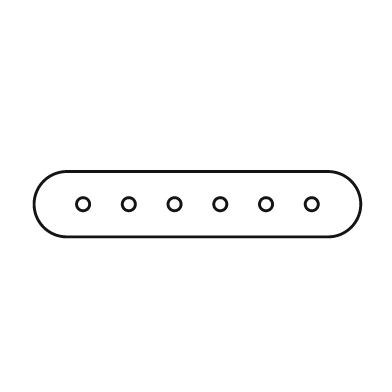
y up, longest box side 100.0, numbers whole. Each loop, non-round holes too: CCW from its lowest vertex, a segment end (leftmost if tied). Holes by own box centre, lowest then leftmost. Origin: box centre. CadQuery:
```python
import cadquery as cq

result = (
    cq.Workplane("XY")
    .moveTo(-40.0, -10.0)
    .lineTo(40.0, -10.0)
    .threePointArc((50.0, 0.0), (40.0, 10.0))
    .lineTo(-40.0, 10.0)
    .threePointArc((-50.0, 0.0), (-40.0, -10.0))
    .close()
    .moveTo(-35.0, 0.0)
    .circle(2.0)
    .moveTo(-21.0, 0.0)
    .circle(2.0)
    .moveTo(-7.0, 0.0)
    .circle(2.0)
    .moveTo(7.0, 0.0)
    .circle(2.0)
    .moveTo(21.0, 0.0)
    .circle(2.0)
    .moveTo(35.0, 0.0)
    .circle(2.0)
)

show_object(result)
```